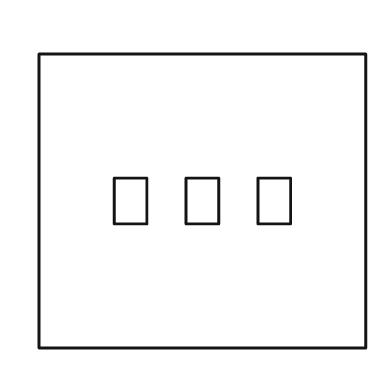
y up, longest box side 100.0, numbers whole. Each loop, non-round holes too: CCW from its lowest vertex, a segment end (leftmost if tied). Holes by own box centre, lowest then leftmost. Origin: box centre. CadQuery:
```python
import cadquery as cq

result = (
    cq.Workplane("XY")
    .moveTo(-50.0, -45.0)
    .lineTo(50.0, -45.0)
    .lineTo(50.0, 45.0)
    .lineTo(-50.0, 45.0)
    .close()
    .moveTo(-27.0, -7.0)
    .lineTo(-17.0, -7.0)
    .lineTo(-17.0, 7.0)
    .lineTo(-27.0, 7.0)
    .close()
    .moveTo(-5.0, -7.0)
    .lineTo(5.0, -7.0)
    .lineTo(5.0, 7.0)
    .lineTo(-5.0, 7.0)
    .close()
    .moveTo(17.0, -7.0)
    .lineTo(27.0, -7.0)
    .lineTo(27.0, 7.0)
    .lineTo(17.0, 7.0)
    .close()
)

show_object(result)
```